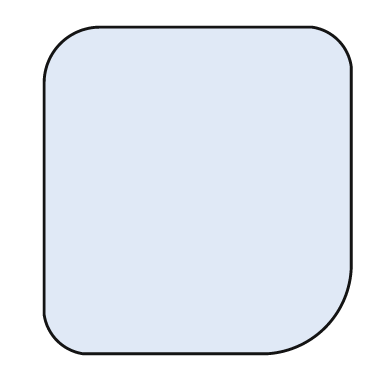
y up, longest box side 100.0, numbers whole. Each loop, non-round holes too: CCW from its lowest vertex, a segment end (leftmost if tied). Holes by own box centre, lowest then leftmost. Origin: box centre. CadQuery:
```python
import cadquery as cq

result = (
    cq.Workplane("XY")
    .moveTo(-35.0, -50.0)
    .lineTo(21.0, -50.0)
    .threePointArc((39.0, -42.0), (47.0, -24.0))
    .lineTo(47.0, 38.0)
    .threePointArc((43.0, 46.0), (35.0, 50.0))
    .lineTo(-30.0, 50.0)
    .threePointArc((-42.0, 45.0), (-47.0, 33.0))
    .lineTo(-47.0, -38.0)
    .threePointArc((-43.0, -46.0), (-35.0, -50.0))
    .close()
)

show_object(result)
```